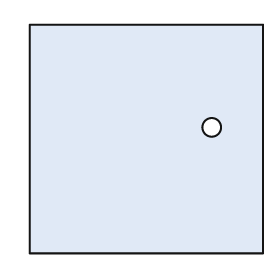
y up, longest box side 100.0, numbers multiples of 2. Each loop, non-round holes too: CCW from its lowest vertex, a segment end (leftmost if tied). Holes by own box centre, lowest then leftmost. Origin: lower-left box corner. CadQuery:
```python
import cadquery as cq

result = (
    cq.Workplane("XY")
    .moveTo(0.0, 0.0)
    .lineTo(100.0, 0.0)
    .lineTo(100.0, 98.0)
    .lineTo(0.0, 98.0)
    .close()
    .moveTo(78.0, 54.0)
    .circle(4.0)
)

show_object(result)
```